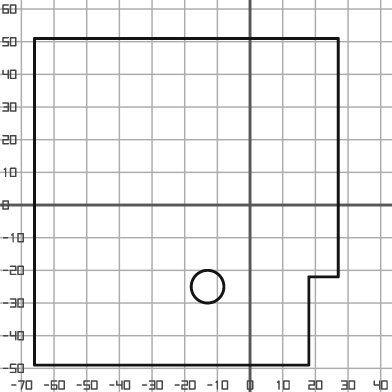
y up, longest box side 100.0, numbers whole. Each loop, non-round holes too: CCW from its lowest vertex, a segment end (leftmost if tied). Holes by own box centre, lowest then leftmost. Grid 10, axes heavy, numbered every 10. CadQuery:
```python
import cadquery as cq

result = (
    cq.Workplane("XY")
    .moveTo(-66.0, -49.0)
    .lineTo(18.0, -49.0)
    .lineTo(18.0, -22.0)
    .lineTo(27.0, -22.0)
    .lineTo(27.0, 51.0)
    .lineTo(-66.0, 51.0)
    .close()
    .moveTo(-13.0, -25.0)
    .circle(5.0)
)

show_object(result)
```